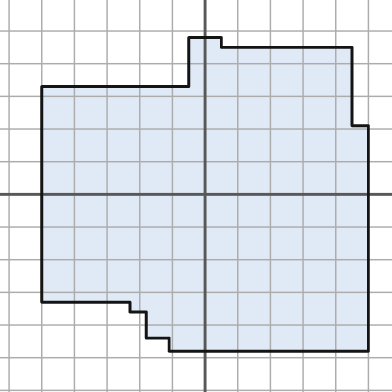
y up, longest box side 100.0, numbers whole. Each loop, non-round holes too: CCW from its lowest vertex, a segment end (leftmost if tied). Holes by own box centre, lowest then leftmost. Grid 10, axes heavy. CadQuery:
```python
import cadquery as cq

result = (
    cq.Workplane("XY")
    .moveTo(-11.0, -48.0)
    .lineTo(50.0, -48.0)
    .lineTo(50.0, 21.0)
    .lineTo(45.0, 21.0)
    .lineTo(45.0, 45.0)
    .lineTo(5.0, 45.0)
    .lineTo(5.0, 48.0)
    .lineTo(-5.0, 48.0)
    .lineTo(-5.0, 33.0)
    .lineTo(-50.0, 33.0)
    .lineTo(-50.0, -33.0)
    .lineTo(-23.0, -33.0)
    .lineTo(-23.0, -36.0)
    .lineTo(-18.0, -36.0)
    .lineTo(-18.0, -44.0)
    .lineTo(-11.0, -44.0)
    .close()
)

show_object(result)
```